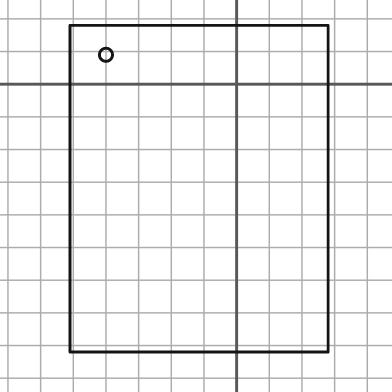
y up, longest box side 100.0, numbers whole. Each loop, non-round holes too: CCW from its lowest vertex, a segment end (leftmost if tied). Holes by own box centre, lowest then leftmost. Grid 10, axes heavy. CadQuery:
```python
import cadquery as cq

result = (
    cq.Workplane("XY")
    .moveTo(-51.0, -82.0)
    .lineTo(28.0, -82.0)
    .lineTo(28.0, 18.0)
    .lineTo(-51.0, 18.0)
    .close()
    .moveTo(-40.0, 9.0)
    .circle(2.0)
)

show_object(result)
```